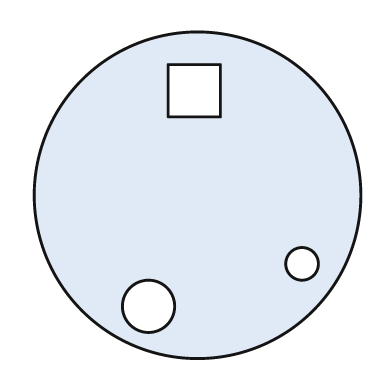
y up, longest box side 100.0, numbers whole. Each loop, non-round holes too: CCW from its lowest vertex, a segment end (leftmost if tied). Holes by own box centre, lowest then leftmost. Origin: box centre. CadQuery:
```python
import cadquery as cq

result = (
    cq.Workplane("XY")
    .moveTo(0.0, 0.0)
    .circle(50.0)
    .moveTo(-15.0, -34.0)
    .circle(8.0)
    .moveTo(32.0, -21.0)
    .circle(5.0)
    .moveTo(-9.0, 24.0)
    .lineTo(7.0, 24.0)
    .lineTo(7.0, 40.0)
    .lineTo(-9.0, 40.0)
    .close()
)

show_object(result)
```